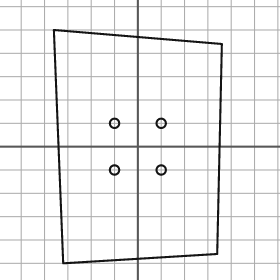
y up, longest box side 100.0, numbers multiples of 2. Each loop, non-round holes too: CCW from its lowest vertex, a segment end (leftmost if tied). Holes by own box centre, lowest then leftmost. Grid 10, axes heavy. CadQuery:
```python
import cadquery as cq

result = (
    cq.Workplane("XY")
    .moveTo(-32.0, -50.0)
    .lineTo(34.0, -46.0)
    .lineTo(36.0, 44.0)
    .lineTo(-36.0, 50.0)
    .close()
    .moveTo(-10.0, -10.0)
    .circle(2.0)
    .moveTo(10.0, -10.0)
    .circle(2.0)
    .moveTo(-10.0, 10.0)
    .circle(2.0)
    .moveTo(10.0, 10.0)
    .circle(2.0)
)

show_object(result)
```